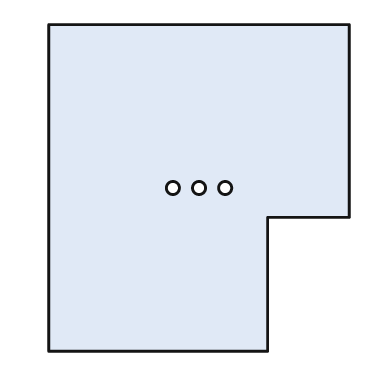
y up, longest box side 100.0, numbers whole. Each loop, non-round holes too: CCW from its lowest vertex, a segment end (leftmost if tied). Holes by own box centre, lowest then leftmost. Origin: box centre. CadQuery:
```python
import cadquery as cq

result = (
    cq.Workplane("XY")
    .moveTo(-46.0, -50.0)
    .lineTo(21.0, -50.0)
    .lineTo(21.0, -9.0)
    .lineTo(46.0, -9.0)
    .lineTo(46.0, 50.0)
    .lineTo(-46.0, 50.0)
    .close()
    .moveTo(-8.0, 0.0)
    .circle(2.0)
    .moveTo(0.0, 0.0)
    .circle(2.0)
    .moveTo(8.0, 0.0)
    .circle(2.0)
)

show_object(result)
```